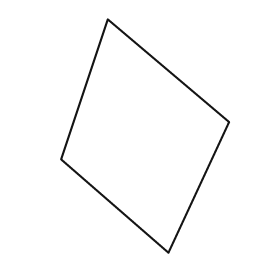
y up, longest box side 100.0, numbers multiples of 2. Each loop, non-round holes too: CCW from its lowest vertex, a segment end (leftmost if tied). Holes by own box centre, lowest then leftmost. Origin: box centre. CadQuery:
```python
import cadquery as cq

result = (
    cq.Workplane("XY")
    .moveTo(10.0, -50.0)
    .lineTo(36.0, 6.0)
    .lineTo(-16.0, 50.0)
    .lineTo(-36.0, -10.0)
    .close()
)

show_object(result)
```